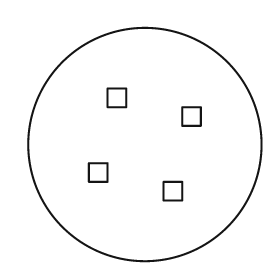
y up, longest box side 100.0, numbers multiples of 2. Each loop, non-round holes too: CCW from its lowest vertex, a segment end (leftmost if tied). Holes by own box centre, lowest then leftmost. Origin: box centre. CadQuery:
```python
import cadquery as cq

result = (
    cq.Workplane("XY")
    .moveTo(0.0, 0.0)
    .circle(50.0)
    .moveTo(8.0, -24.0)
    .lineTo(16.0, -24.0)
    .lineTo(16.0, -16.0)
    .lineTo(8.0, -16.0)
    .close()
    .moveTo(-24.0, -16.0)
    .lineTo(-16.0, -16.0)
    .lineTo(-16.0, -8.0)
    .lineTo(-24.0, -8.0)
    .close()
    .moveTo(16.0, 8.0)
    .lineTo(24.0, 8.0)
    .lineTo(24.0, 16.0)
    .lineTo(16.0, 16.0)
    .close()
    .moveTo(-16.0, 16.0)
    .lineTo(-8.0, 16.0)
    .lineTo(-8.0, 24.0)
    .lineTo(-16.0, 24.0)
    .close()
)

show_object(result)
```